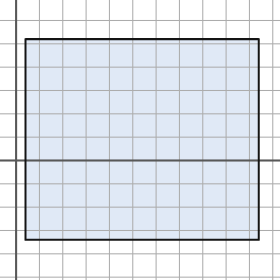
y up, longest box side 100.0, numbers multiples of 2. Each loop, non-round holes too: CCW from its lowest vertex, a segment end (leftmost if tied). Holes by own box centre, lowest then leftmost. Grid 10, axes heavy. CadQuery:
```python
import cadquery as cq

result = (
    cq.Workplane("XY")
    .moveTo(4.0, -34.0)
    .lineTo(104.0, -34.0)
    .lineTo(104.0, 52.0)
    .lineTo(4.0, 52.0)
    .close()
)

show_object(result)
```